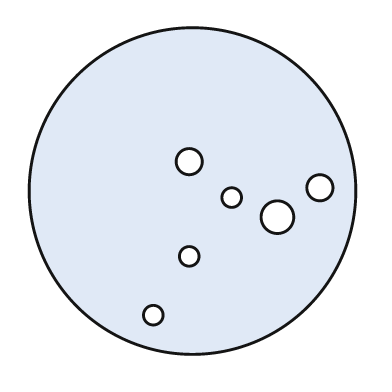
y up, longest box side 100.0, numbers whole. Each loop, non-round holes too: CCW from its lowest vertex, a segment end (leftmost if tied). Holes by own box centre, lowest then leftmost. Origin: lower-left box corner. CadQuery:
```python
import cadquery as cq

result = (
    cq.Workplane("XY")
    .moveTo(50.0, 50.0)
    .circle(50.0)
    .moveTo(38.0, 12.0)
    .circle(3.0)
    .moveTo(49.0, 30.0)
    .circle(3.0)
    .moveTo(76.0, 42.0)
    .circle(5.0)
    .moveTo(62.0, 48.0)
    .circle(3.0)
    .moveTo(89.0, 51.0)
    .circle(4.0)
    .moveTo(49.0, 59.0)
    .circle(4.0)
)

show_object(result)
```